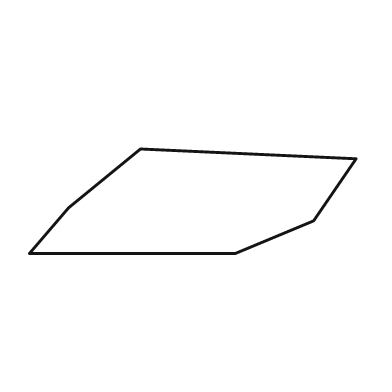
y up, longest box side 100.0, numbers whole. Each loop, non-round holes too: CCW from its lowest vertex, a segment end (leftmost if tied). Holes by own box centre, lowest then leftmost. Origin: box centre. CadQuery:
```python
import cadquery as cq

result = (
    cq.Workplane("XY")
    .moveTo(-50.0, -16.0)
    .lineTo(13.0, -16.0)
    .lineTo(37.0, -6.0)
    .lineTo(50.0, 13.0)
    .lineTo(-16.0, 16.0)
    .lineTo(-38.0, -2.0)
    .close()
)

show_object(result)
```